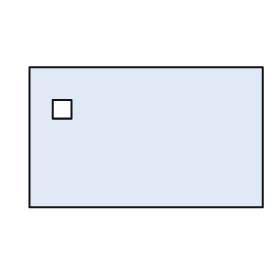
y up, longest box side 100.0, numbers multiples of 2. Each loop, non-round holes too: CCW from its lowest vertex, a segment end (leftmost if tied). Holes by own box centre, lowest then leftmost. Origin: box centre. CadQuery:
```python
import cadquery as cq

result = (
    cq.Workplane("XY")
    .moveTo(-50.0, -30.0)
    .lineTo(50.0, -30.0)
    .lineTo(50.0, 30.0)
    .lineTo(-50.0, 30.0)
    .close()
    .moveTo(-40.0, 8.0)
    .lineTo(-32.0, 8.0)
    .lineTo(-32.0, 16.0)
    .lineTo(-40.0, 16.0)
    .close()
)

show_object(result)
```